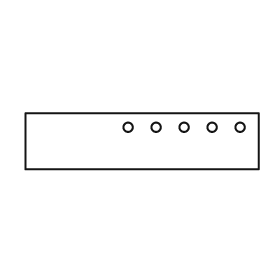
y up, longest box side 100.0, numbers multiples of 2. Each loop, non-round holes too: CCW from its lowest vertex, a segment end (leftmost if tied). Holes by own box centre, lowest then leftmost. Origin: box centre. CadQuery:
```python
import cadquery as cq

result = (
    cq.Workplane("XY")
    .moveTo(-50.0, -12.0)
    .lineTo(50.0, -12.0)
    .lineTo(50.0, 12.0)
    .lineTo(-50.0, 12.0)
    .close()
    .moveTo(-6.0, 6.0)
    .circle(2.0)
    .moveTo(6.0, 6.0)
    .circle(2.0)
    .moveTo(18.0, 6.0)
    .circle(2.0)
    .moveTo(30.0, 6.0)
    .circle(2.0)
    .moveTo(42.0, 6.0)
    .circle(2.0)
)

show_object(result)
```